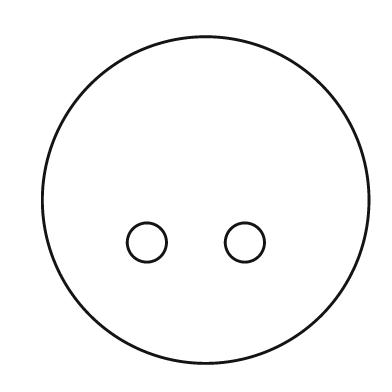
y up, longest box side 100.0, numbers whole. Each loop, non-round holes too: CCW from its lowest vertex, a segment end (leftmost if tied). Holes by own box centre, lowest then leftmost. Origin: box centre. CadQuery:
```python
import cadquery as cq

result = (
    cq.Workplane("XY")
    .moveTo(0.0, 0.0)
    .circle(50.0)
    .moveTo(-18.0, -13.0)
    .circle(6.0)
    .moveTo(12.0, -13.0)
    .circle(6.0)
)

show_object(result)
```